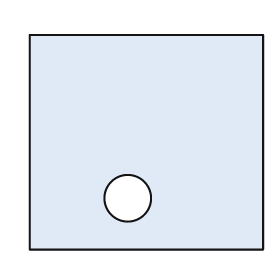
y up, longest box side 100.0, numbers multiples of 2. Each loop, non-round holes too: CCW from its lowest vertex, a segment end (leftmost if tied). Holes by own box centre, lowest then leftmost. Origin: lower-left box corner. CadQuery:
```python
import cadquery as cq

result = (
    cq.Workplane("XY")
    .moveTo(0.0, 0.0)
    .lineTo(100.0, 0.0)
    .lineTo(100.0, 92.0)
    .lineTo(0.0, 92.0)
    .close()
    .moveTo(42.0, 22.0)
    .circle(10.0)
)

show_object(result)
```